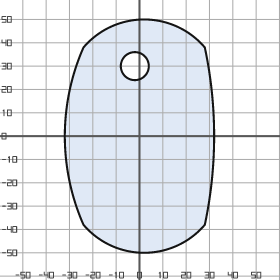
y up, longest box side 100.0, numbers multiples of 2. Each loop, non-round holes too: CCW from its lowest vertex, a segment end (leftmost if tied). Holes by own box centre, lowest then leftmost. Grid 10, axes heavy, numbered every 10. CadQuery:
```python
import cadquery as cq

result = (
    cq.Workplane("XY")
    .moveTo(-24.0, -38.0)
    .threePointArc((2.0, -50.0), (28.0, -38.0))
    .threePointArc((32.0, 0.0), (28.0, 38.0))
    .threePointArc((2.0, 50.0), (-24.0, 38.0))
    .threePointArc((-32.0, 0.0), (-24.0, -38.0))
    .close()
    .moveTo(-2.0, 30.0)
    .circle(6.0)
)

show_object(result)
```